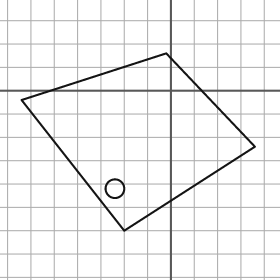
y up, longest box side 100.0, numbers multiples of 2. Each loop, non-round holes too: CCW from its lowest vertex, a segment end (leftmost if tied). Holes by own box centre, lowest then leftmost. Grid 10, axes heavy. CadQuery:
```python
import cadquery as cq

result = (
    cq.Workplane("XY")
    .moveTo(-20.0, -60.0)
    .lineTo(36.0, -24.0)
    .lineTo(-2.0, 16.0)
    .lineTo(-64.0, -4.0)
    .close()
    .moveTo(-24.0, -42.0)
    .circle(4.0)
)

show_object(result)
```